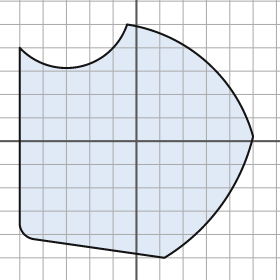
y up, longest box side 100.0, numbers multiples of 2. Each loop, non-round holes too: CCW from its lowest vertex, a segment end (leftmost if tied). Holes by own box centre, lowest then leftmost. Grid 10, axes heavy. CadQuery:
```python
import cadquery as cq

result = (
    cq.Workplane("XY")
    .moveTo(12.0, -50.0)
    .threePointArc((36.0, -28.0), (50.0, 2.0))
    .threePointArc((30.0, 34.0), (-4.0, 50.0))
    .threePointArc((-24.0, 32.0), (-50.0, 40.0))
    .lineTo(-50.0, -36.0)
    .threePointArc((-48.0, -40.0), (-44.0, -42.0))
    .close()
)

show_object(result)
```